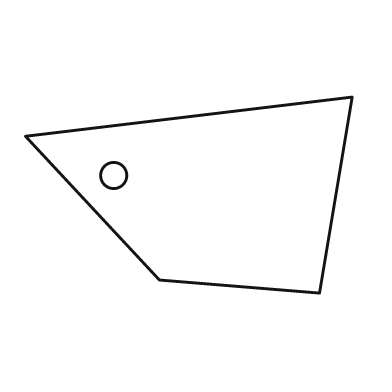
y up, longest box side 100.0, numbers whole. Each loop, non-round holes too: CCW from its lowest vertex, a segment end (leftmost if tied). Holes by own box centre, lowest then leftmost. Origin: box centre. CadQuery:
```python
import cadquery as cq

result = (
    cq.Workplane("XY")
    .moveTo(40.0, -30.0)
    .lineTo(50.0, 30.0)
    .lineTo(-50.0, 18.0)
    .lineTo(-9.0, -26.0)
    .close()
    .moveTo(-23.0, 6.0)
    .circle(4.0)
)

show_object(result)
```